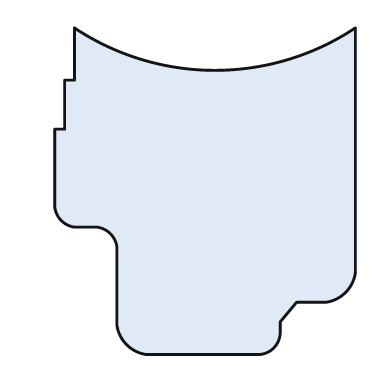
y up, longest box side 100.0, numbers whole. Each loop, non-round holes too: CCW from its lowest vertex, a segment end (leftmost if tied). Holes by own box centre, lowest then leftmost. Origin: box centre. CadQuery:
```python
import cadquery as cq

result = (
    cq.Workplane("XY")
    .moveTo(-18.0, -50.0)
    .lineTo(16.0, -50.0)
    .threePointArc((21.0, -48.0), (23.0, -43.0))
    .lineTo(23.0, -40.0)
    .lineTo(28.0, -34.0)
    .lineTo(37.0, -34.0)
    .threePointArc((43.0, -31.0), (46.0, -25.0))
    .lineTo(46.0, 50.0)
    .threePointArc((3.0, 37.0), (-40.0, 50.0))
    .lineTo(-40.0, 34.0)
    .lineTo(-43.0, 34.0)
    .lineTo(-43.0, 19.0)
    .lineTo(-46.0, 19.0)
    .lineTo(-46.0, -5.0)
    .threePointArc((-44.0, -9.0), (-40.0, -11.0))
    .lineTo(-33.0, -11.0)
    .threePointArc((-29.0, -13.0), (-27.0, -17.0))
    .lineTo(-27.0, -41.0)
    .threePointArc((-24.0, -47.0), (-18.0, -50.0))
    .close()
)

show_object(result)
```